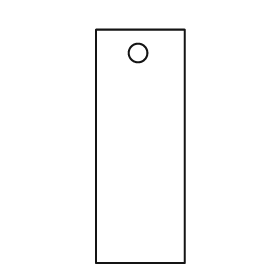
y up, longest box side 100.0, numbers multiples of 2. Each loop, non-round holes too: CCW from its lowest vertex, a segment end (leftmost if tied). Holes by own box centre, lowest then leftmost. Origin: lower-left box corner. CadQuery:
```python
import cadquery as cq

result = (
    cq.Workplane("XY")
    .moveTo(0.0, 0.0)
    .lineTo(38.0, 0.0)
    .lineTo(38.0, 100.0)
    .lineTo(0.0, 100.0)
    .close()
    .moveTo(18.0, 90.0)
    .circle(4.0)
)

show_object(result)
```